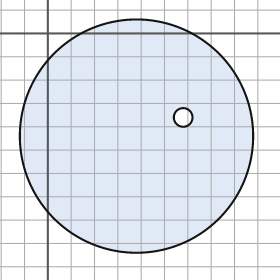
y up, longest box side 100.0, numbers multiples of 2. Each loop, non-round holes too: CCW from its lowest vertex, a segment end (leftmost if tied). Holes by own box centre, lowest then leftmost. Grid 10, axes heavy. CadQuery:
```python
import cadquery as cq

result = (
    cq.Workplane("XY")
    .moveTo(38.0, -44.0)
    .circle(50.0)
    .moveTo(58.0, -36.0)
    .circle(4.0)
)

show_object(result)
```